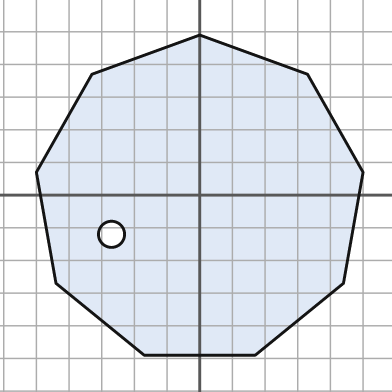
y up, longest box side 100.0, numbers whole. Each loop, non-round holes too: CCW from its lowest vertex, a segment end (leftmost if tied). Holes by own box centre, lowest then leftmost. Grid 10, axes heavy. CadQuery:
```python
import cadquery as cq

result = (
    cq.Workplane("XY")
    .moveTo(-17.0, -49.0)
    .lineTo(17.0, -49.0)
    .lineTo(44.0, -27.0)
    .lineTo(50.0, 7.0)
    .lineTo(33.0, 37.0)
    .lineTo(0.0, 49.0)
    .lineTo(-33.0, 37.0)
    .lineTo(-50.0, 7.0)
    .lineTo(-44.0, -27.0)
    .close()
    .moveTo(-27.0, -12.0)
    .circle(4.0)
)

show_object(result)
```